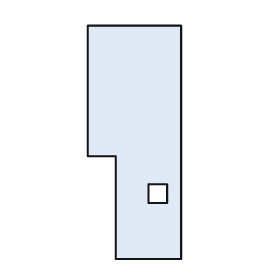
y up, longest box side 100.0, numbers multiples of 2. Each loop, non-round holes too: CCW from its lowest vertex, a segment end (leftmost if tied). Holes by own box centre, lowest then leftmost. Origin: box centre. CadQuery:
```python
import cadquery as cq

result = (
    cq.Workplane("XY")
    .moveTo(-8.0, -50.0)
    .lineTo(20.0, -50.0)
    .lineTo(20.0, 50.0)
    .lineTo(-20.0, 50.0)
    .lineTo(-20.0, -6.0)
    .lineTo(-8.0, -6.0)
    .close()
    .moveTo(6.0, -26.0)
    .lineTo(14.0, -26.0)
    .lineTo(14.0, -18.0)
    .lineTo(6.0, -18.0)
    .close()
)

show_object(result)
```